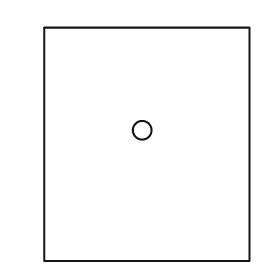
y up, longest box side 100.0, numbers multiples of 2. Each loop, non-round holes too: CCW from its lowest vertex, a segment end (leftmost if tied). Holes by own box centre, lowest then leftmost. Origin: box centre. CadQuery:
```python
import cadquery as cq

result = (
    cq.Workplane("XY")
    .moveTo(-44.0, -50.0)
    .lineTo(44.0, -50.0)
    .lineTo(44.0, 50.0)
    .lineTo(-44.0, 50.0)
    .close()
    .moveTo(-2.0, 6.0)
    .circle(4.0)
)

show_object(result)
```